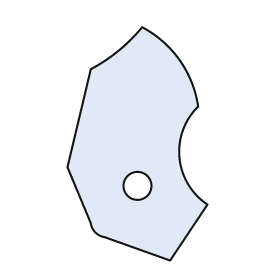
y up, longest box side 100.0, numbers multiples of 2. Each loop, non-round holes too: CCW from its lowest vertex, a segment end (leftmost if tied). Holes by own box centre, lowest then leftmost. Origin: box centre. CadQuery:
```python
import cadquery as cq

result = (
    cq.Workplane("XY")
    .moveTo(14.0, -50.0)
    .lineTo(30.0, -26.0)
    .threePointArc((18.0, -6.0), (26.0, 16.0))
    .threePointArc((18.0, 36.0), (2.0, 50.0))
    .threePointArc((-8.0, 40.0), (-20.0, 32.0))
    .lineTo(-30.0, -10.0)
    .lineTo(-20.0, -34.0)
    .threePointArc((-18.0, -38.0), (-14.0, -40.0))
    .close()
    .moveTo(0.0, -18.0)
    .circle(6.0)
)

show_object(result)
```